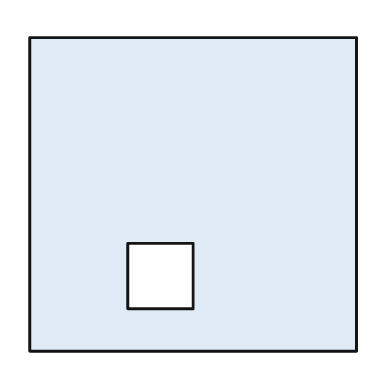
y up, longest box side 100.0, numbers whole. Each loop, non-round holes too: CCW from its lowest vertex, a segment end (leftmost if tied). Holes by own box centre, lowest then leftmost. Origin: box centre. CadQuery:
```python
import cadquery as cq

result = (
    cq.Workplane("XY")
    .moveTo(-50.0, -48.0)
    .lineTo(50.0, -48.0)
    .lineTo(50.0, 48.0)
    .lineTo(-50.0, 48.0)
    .close()
    .moveTo(-20.0, -35.0)
    .lineTo(0.0, -35.0)
    .lineTo(0.0, -15.0)
    .lineTo(-20.0, -15.0)
    .close()
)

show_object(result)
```